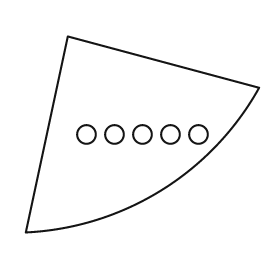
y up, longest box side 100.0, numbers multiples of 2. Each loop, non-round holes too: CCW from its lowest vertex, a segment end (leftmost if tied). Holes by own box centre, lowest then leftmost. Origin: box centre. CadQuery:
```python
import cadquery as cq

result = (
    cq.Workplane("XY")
    .moveTo(-50.0, -42.0)
    .threePointArc((8.0, -24.0), (50.0, 20.0))
    .lineTo(-32.0, 42.0)
    .close()
    .moveTo(-24.0, 0.0)
    .circle(4.0)
    .moveTo(-12.0, 0.0)
    .circle(4.0)
    .moveTo(0.0, 0.0)
    .circle(4.0)
    .moveTo(12.0, 0.0)
    .circle(4.0)
    .moveTo(24.0, 0.0)
    .circle(4.0)
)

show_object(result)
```